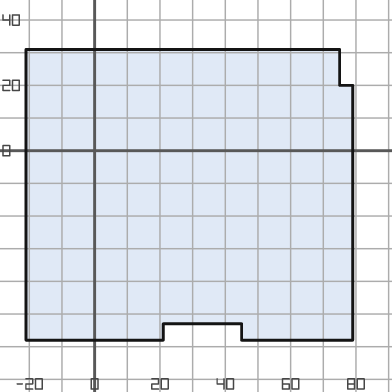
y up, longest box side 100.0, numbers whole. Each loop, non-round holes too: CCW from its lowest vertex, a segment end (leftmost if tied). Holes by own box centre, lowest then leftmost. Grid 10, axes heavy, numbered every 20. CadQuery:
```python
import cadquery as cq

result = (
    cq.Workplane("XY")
    .moveTo(-21.0, -58.0)
    .lineTo(21.0, -58.0)
    .lineTo(21.0, -53.0)
    .lineTo(45.0, -53.0)
    .lineTo(45.0, -58.0)
    .lineTo(79.0, -58.0)
    .lineTo(79.0, 20.0)
    .lineTo(75.0, 20.0)
    .lineTo(75.0, 31.0)
    .lineTo(-21.0, 31.0)
    .close()
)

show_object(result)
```